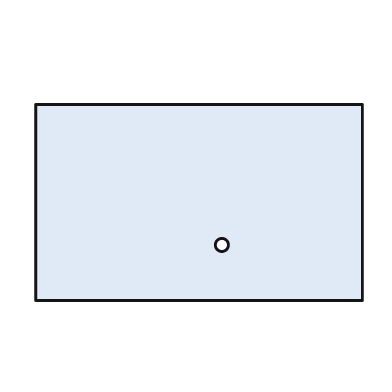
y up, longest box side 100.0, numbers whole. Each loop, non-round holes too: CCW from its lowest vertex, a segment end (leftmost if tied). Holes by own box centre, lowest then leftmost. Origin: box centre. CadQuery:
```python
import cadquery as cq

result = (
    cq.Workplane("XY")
    .moveTo(-50.0, -30.0)
    .lineTo(50.0, -30.0)
    .lineTo(50.0, 30.0)
    .lineTo(-50.0, 30.0)
    .close()
    .moveTo(7.0, -13.0)
    .circle(2.0)
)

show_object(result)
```